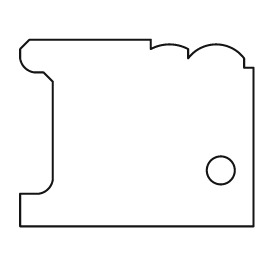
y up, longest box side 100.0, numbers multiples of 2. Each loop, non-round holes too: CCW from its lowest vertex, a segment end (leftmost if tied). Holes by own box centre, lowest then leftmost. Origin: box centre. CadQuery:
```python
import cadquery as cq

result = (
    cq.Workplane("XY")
    .moveTo(-50.0, -40.0)
    .lineTo(50.0, -40.0)
    .lineTo(50.0, 28.0)
    .lineTo(46.0, 28.0)
    .lineTo(46.0, 32.0)
    .threePointArc((34.0, 38.0), (22.0, 32.0))
    .lineTo(22.0, 36.0)
    .threePointArc((14.0, 38.0), (6.0, 36.0))
    .lineTo(6.0, 40.0)
    .lineTo(-46.0, 40.0)
    .lineTo(-50.0, 36.0)
    .lineTo(-50.0, 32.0)
    .threePointArc((-48.0, 28.0), (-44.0, 26.0))
    .lineTo(-40.0, 26.0)
    .lineTo(-36.0, 22.0)
    .lineTo(-36.0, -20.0)
    .threePointArc((-38.0, -24.0), (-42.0, -26.0))
    .lineTo(-50.0, -26.0)
    .close()
    .moveTo(36.0, -16.0)
    .circle(6.0)
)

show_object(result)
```